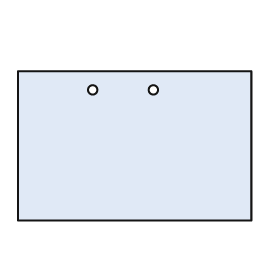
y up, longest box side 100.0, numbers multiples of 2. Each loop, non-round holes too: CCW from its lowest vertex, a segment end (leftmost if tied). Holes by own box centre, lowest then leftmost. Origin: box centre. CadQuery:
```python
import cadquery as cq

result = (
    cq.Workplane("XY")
    .moveTo(-50.0, -32.0)
    .lineTo(50.0, -32.0)
    .lineTo(50.0, 32.0)
    .lineTo(-50.0, 32.0)
    .close()
    .moveTo(-18.0, 24.0)
    .circle(2.0)
    .moveTo(8.0, 24.0)
    .circle(2.0)
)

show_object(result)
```